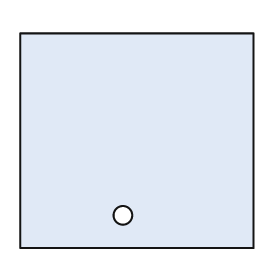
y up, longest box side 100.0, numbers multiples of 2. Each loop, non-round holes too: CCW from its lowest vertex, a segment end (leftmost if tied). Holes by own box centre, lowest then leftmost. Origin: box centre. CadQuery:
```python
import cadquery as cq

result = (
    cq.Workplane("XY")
    .moveTo(-50.0, -46.0)
    .lineTo(50.0, -46.0)
    .lineTo(50.0, 46.0)
    .lineTo(-50.0, 46.0)
    .close()
    .moveTo(-6.0, -32.0)
    .circle(4.0)
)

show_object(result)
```